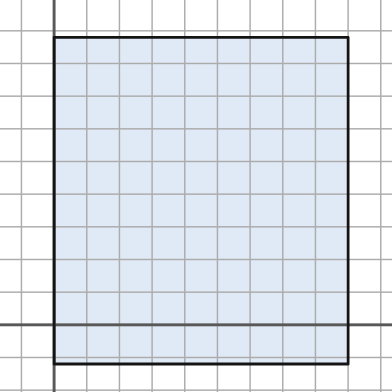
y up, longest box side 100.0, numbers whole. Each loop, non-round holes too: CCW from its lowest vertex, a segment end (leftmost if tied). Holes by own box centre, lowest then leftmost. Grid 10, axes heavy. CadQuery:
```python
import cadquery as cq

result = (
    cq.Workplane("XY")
    .moveTo(0.0, -12.0)
    .lineTo(90.0, -12.0)
    .lineTo(90.0, 88.0)
    .lineTo(0.0, 88.0)
    .close()
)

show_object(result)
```